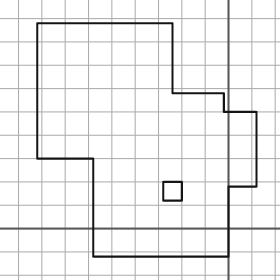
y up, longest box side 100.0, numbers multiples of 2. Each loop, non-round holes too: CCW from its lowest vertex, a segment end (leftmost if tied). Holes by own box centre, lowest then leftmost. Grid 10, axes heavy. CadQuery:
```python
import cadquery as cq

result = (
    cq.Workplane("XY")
    .moveTo(-58.0, -12.0)
    .lineTo(0.0, -12.0)
    .lineTo(0.0, 18.0)
    .lineTo(12.0, 18.0)
    .lineTo(12.0, 50.0)
    .lineTo(-2.0, 50.0)
    .lineTo(-2.0, 58.0)
    .lineTo(-24.0, 58.0)
    .lineTo(-24.0, 88.0)
    .lineTo(-82.0, 88.0)
    .lineTo(-82.0, 30.0)
    .lineTo(-58.0, 30.0)
    .close()
    .moveTo(-28.0, 12.0)
    .lineTo(-20.0, 12.0)
    .lineTo(-20.0, 20.0)
    .lineTo(-28.0, 20.0)
    .close()
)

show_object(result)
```